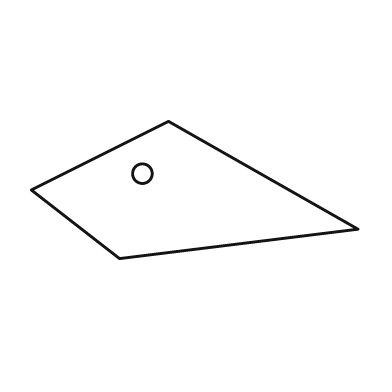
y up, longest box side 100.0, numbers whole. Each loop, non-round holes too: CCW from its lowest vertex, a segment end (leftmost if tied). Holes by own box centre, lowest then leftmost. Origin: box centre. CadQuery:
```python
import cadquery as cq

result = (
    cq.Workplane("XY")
    .moveTo(-23.0, -21.0)
    .lineTo(50.0, -12.0)
    .lineTo(-8.0, 21.0)
    .lineTo(-50.0, 0.0)
    .close()
    .moveTo(-16.0, 5.0)
    .circle(3.0)
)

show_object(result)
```